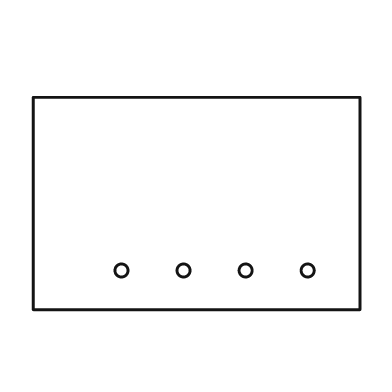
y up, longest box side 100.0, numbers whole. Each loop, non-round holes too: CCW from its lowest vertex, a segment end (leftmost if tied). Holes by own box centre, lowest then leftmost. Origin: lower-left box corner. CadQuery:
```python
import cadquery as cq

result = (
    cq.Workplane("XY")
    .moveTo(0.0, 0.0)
    .lineTo(100.0, 0.0)
    .lineTo(100.0, 65.0)
    .lineTo(0.0, 65.0)
    .close()
    .moveTo(27.0, 12.0)
    .circle(2.0)
    .moveTo(46.0, 12.0)
    .circle(2.0)
    .moveTo(65.0, 12.0)
    .circle(2.0)
    .moveTo(84.0, 12.0)
    .circle(2.0)
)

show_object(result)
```